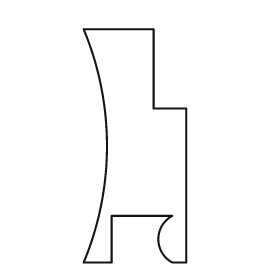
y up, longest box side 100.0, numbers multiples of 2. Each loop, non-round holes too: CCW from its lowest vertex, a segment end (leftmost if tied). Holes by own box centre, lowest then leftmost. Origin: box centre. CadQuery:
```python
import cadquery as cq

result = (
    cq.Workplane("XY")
    .moveTo(-22.0, -50.0)
    .lineTo(-10.0, -50.0)
    .lineTo(-10.0, -30.0)
    .lineTo(16.0, -30.0)
    .threePointArc((10.0, -40.0), (16.0, -50.0))
    .lineTo(22.0, -50.0)
    .lineTo(22.0, 16.0)
    .lineTo(8.0, 16.0)
    .lineTo(8.0, 50.0)
    .lineTo(-22.0, 50.0)
    .threePointArc((-12.0, 0.0), (-22.0, -50.0))
    .close()
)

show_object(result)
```